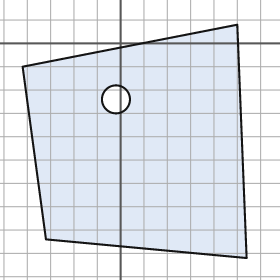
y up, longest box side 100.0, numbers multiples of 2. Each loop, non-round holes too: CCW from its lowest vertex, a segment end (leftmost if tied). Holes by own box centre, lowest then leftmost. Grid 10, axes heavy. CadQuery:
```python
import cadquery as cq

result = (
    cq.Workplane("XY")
    .moveTo(54.0, -92.0)
    .lineTo(50.0, 8.0)
    .lineTo(-42.0, -10.0)
    .lineTo(-32.0, -84.0)
    .close()
    .moveTo(-2.0, -24.0)
    .circle(6.0)
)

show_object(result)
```